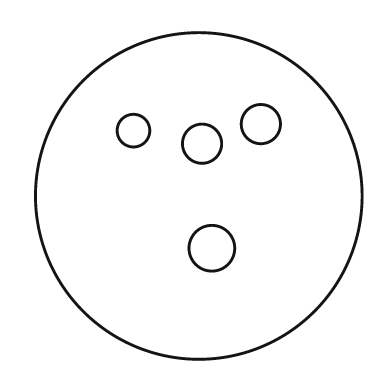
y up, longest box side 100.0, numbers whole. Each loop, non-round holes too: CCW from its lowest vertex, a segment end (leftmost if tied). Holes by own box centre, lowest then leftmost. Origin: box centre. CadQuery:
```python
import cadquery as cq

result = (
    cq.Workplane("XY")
    .moveTo(0.0, 0.0)
    .circle(50.0)
    .moveTo(4.0, -16.0)
    .circle(7.0)
    .moveTo(1.0, 16.0)
    .circle(6.0)
    .moveTo(-20.0, 20.0)
    .circle(5.0)
    .moveTo(19.0, 22.0)
    .circle(6.0)
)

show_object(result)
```